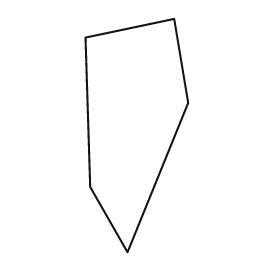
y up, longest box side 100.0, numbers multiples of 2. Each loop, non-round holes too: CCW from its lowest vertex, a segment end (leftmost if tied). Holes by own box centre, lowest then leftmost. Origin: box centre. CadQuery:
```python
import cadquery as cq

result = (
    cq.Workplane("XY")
    .moveTo(-4.0, -50.0)
    .lineTo(22.0, 14.0)
    .lineTo(16.0, 50.0)
    .lineTo(-22.0, 42.0)
    .lineTo(-20.0, -22.0)
    .close()
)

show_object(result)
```